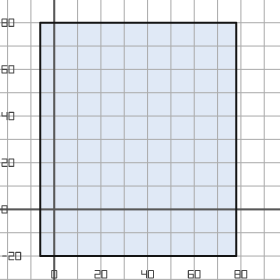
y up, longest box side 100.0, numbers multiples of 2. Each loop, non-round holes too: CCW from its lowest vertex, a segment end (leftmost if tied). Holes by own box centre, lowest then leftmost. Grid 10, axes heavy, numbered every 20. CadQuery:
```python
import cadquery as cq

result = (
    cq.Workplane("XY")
    .moveTo(-6.0, -20.0)
    .lineTo(78.0, -20.0)
    .lineTo(78.0, 80.0)
    .lineTo(-6.0, 80.0)
    .close()
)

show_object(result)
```